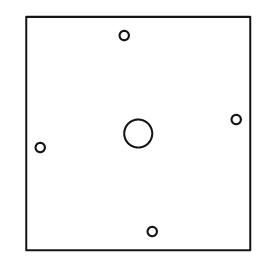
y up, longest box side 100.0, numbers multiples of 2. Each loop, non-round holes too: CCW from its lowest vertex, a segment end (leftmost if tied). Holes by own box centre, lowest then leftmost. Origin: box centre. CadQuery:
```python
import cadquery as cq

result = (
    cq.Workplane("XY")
    .moveTo(-48.0, -50.0)
    .lineTo(48.0, -50.0)
    .lineTo(48.0, 50.0)
    .lineTo(-48.0, 50.0)
    .close()
    .moveTo(6.0, -42.0)
    .circle(2.0)
    .moveTo(-42.0, -6.0)
    .circle(2.0)
    .moveTo(0.0, 0.0)
    .circle(6.0)
    .moveTo(42.0, 6.0)
    .circle(2.0)
    .moveTo(-6.0, 42.0)
    .circle(2.0)
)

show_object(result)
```